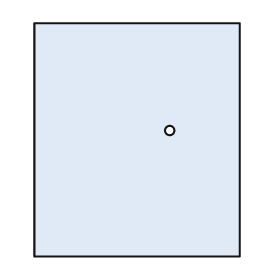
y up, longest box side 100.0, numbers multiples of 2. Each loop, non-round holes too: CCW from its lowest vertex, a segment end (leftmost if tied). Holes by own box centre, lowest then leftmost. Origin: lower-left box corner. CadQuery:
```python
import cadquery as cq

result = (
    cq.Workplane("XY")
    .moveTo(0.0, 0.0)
    .lineTo(88.0, 0.0)
    .lineTo(88.0, 100.0)
    .lineTo(0.0, 100.0)
    .close()
    .moveTo(58.0, 54.0)
    .circle(2.0)
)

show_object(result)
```